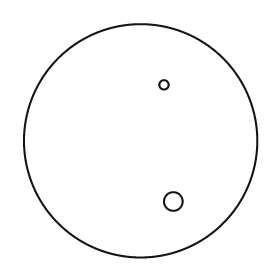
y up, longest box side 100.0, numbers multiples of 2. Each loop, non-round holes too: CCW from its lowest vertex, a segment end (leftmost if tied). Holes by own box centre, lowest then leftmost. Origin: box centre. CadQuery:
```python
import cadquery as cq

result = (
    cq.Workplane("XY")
    .moveTo(0.0, 0.0)
    .circle(50.0)
    .moveTo(14.0, -26.0)
    .circle(4.0)
    .moveTo(10.0, 24.0)
    .circle(2.0)
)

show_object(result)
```